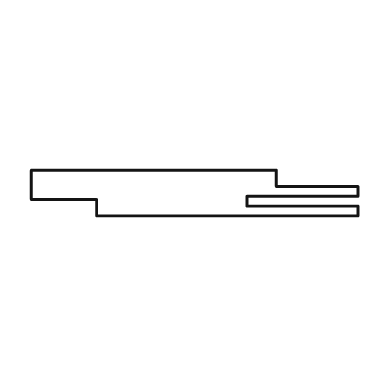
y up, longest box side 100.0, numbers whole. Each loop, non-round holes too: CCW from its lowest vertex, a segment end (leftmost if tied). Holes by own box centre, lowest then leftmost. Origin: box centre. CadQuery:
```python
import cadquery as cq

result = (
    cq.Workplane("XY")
    .moveTo(-30.0, -7.0)
    .lineTo(50.0, -7.0)
    .lineTo(50.0, -4.0)
    .lineTo(16.0, -4.0)
    .lineTo(16.0, -1.0)
    .lineTo(50.0, -1.0)
    .lineTo(50.0, 2.0)
    .lineTo(25.0, 2.0)
    .lineTo(25.0, 7.0)
    .lineTo(-50.0, 7.0)
    .lineTo(-50.0, -2.0)
    .lineTo(-30.0, -2.0)
    .close()
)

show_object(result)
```